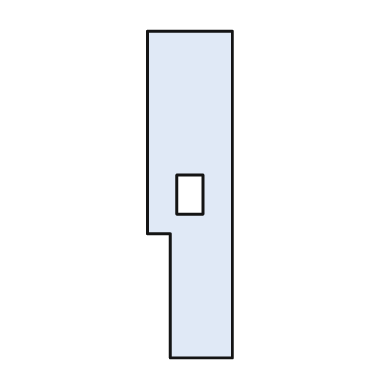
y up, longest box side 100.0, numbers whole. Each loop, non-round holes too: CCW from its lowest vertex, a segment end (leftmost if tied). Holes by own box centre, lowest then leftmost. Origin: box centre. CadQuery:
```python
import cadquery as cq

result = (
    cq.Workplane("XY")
    .moveTo(-6.0, -50.0)
    .lineTo(13.0, -50.0)
    .lineTo(13.0, 50.0)
    .lineTo(-13.0, 50.0)
    .lineTo(-13.0, -12.0)
    .lineTo(-6.0, -12.0)
    .close()
    .moveTo(-4.0, -6.0)
    .lineTo(4.0, -6.0)
    .lineTo(4.0, 6.0)
    .lineTo(-4.0, 6.0)
    .close()
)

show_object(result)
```